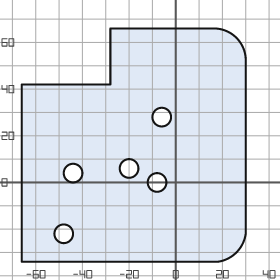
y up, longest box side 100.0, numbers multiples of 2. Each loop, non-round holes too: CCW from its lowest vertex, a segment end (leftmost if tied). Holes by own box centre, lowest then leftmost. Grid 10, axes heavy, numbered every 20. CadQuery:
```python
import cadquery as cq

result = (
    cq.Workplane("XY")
    .moveTo(-66.0, -34.0)
    .lineTo(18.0, -34.0)
    .threePointArc((26.0, -30.0), (30.0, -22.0))
    .lineTo(30.0, 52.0)
    .threePointArc((26.0, 62.0), (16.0, 66.0))
    .lineTo(-28.0, 66.0)
    .lineTo(-28.0, 42.0)
    .lineTo(-66.0, 42.0)
    .close()
    .moveTo(-48.0, -22.0)
    .circle(4.0)
    .moveTo(-8.0, 0.0)
    .circle(4.0)
    .moveTo(-44.0, 4.0)
    .circle(4.0)
    .moveTo(-20.0, 6.0)
    .circle(4.0)
    .moveTo(-6.0, 28.0)
    .circle(4.0)
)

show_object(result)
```